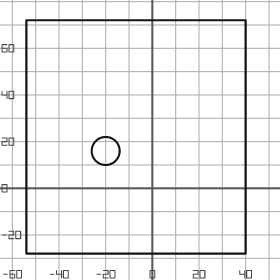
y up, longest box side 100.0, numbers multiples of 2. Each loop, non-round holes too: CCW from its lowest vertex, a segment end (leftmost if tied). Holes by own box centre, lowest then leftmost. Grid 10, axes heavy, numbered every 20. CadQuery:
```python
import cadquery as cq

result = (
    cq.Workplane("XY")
    .moveTo(-54.0, -28.0)
    .lineTo(40.0, -28.0)
    .lineTo(40.0, 72.0)
    .lineTo(-54.0, 72.0)
    .close()
    .moveTo(-20.0, 16.0)
    .circle(6.0)
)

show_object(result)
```